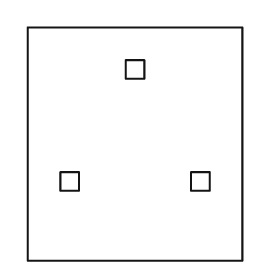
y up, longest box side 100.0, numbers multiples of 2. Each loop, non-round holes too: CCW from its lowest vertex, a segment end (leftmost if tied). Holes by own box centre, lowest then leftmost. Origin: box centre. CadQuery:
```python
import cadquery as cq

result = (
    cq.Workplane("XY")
    .moveTo(-46.0, -50.0)
    .lineTo(46.0, -50.0)
    .lineTo(46.0, 50.0)
    .lineTo(-46.0, 50.0)
    .close()
    .moveTo(-32.0, -20.0)
    .lineTo(-24.0, -20.0)
    .lineTo(-24.0, -12.0)
    .lineTo(-32.0, -12.0)
    .close()
    .moveTo(24.0, -20.0)
    .lineTo(32.0, -20.0)
    .lineTo(32.0, -12.0)
    .lineTo(24.0, -12.0)
    .close()
    .moveTo(-4.0, 28.0)
    .lineTo(4.0, 28.0)
    .lineTo(4.0, 36.0)
    .lineTo(-4.0, 36.0)
    .close()
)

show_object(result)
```